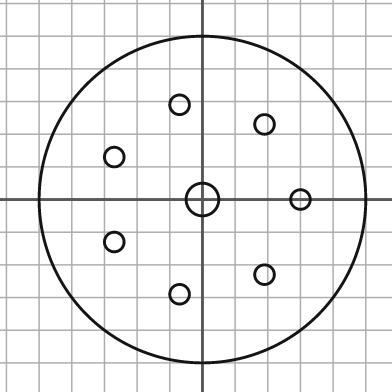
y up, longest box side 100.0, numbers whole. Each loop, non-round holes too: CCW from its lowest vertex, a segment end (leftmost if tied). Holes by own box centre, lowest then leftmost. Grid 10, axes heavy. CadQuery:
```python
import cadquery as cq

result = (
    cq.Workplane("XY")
    .moveTo(0.0, 0.0)
    .circle(50.0)
    .moveTo(-7.0, -29.0)
    .circle(3.0)
    .moveTo(19.0, -23.0)
    .circle(3.0)
    .moveTo(-27.0, -13.0)
    .circle(3.0)
    .moveTo(0.0, 0.0)
    .circle(5.0)
    .moveTo(30.0, 0.0)
    .circle(3.0)
    .moveTo(-27.0, 13.0)
    .circle(3.0)
    .moveTo(19.0, 23.0)
    .circle(3.0)
    .moveTo(-7.0, 29.0)
    .circle(3.0)
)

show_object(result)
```